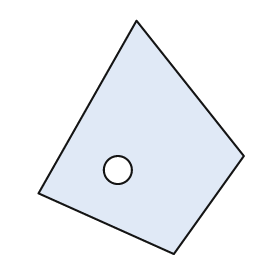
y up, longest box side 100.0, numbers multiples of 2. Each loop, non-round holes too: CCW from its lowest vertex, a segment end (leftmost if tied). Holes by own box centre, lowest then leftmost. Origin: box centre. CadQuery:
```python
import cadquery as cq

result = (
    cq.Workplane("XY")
    .moveTo(14.0, -50.0)
    .lineTo(44.0, -8.0)
    .lineTo(-2.0, 50.0)
    .lineTo(-44.0, -24.0)
    .close()
    .moveTo(-10.0, -14.0)
    .circle(6.0)
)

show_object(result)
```